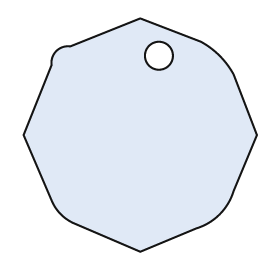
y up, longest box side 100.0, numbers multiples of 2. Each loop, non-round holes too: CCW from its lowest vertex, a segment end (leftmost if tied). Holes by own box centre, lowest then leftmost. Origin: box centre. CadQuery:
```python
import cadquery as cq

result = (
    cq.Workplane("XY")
    .moveTo(0.0, -50.0)
    .lineTo(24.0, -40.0)
    .threePointArc((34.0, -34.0), (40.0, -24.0))
    .lineTo(50.0, 0.0)
    .lineTo(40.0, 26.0)
    .threePointArc((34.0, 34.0), (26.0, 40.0))
    .lineTo(0.0, 50.0)
    .lineTo(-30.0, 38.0)
    .threePointArc((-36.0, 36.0), (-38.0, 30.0))
    .lineTo(-50.0, 0.0)
    .lineTo(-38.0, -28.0)
    .threePointArc((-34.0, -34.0), (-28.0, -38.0))
    .close()
    .moveTo(8.0, 34.0)
    .circle(6.0)
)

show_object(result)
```